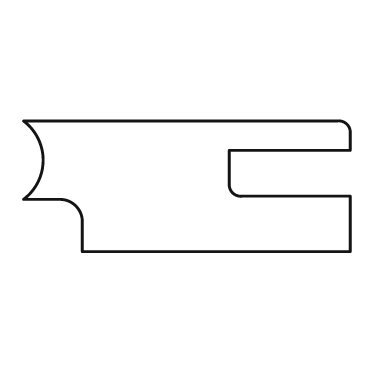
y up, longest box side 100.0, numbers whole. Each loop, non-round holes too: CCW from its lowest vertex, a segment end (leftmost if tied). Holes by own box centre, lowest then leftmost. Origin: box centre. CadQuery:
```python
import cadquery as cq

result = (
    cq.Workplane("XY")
    .moveTo(-32.0, -20.0)
    .lineTo(50.0, -20.0)
    .lineTo(50.0, -3.0)
    .lineTo(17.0, -3.0)
    .threePointArc((14.0, -2.0), (13.0, 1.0))
    .lineTo(13.0, 11.0)
    .lineTo(50.0, 11.0)
    .lineTo(50.0, 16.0)
    .threePointArc((49.0, 19.0), (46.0, 20.0))
    .lineTo(-50.0, 20.0)
    .threePointArc((-44.0, 8.0), (-50.0, -4.0))
    .lineTo(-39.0, -4.0)
    .threePointArc((-34.0, -6.0), (-32.0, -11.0))
    .close()
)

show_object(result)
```